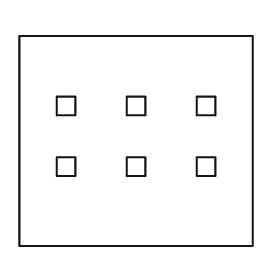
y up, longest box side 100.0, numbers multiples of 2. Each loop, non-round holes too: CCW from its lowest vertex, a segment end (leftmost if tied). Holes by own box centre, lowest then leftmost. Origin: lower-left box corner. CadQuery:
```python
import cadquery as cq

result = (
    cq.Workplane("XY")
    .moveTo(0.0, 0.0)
    .lineTo(100.0, 0.0)
    .lineTo(100.0, 90.0)
    .lineTo(0.0, 90.0)
    .close()
    .moveTo(16.0, 30.0)
    .lineTo(24.0, 30.0)
    .lineTo(24.0, 38.0)
    .lineTo(16.0, 38.0)
    .close()
    .moveTo(46.0, 30.0)
    .lineTo(54.0, 30.0)
    .lineTo(54.0, 38.0)
    .lineTo(46.0, 38.0)
    .close()
    .moveTo(76.0, 30.0)
    .lineTo(84.0, 30.0)
    .lineTo(84.0, 38.0)
    .lineTo(76.0, 38.0)
    .close()
    .moveTo(16.0, 56.0)
    .lineTo(24.0, 56.0)
    .lineTo(24.0, 64.0)
    .lineTo(16.0, 64.0)
    .close()
    .moveTo(46.0, 56.0)
    .lineTo(54.0, 56.0)
    .lineTo(54.0, 64.0)
    .lineTo(46.0, 64.0)
    .close()
    .moveTo(76.0, 56.0)
    .lineTo(84.0, 56.0)
    .lineTo(84.0, 64.0)
    .lineTo(76.0, 64.0)
    .close()
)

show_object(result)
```